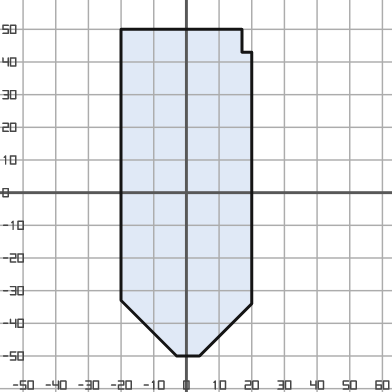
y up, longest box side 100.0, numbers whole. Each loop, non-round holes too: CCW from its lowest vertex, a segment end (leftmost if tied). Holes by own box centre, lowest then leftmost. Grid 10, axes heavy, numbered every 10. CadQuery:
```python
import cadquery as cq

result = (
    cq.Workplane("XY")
    .moveTo(-3.0, -50.0)
    .lineTo(4.0, -50.0)
    .lineTo(20.0, -34.0)
    .lineTo(20.0, 43.0)
    .lineTo(17.0, 43.0)
    .lineTo(17.0, 50.0)
    .lineTo(-20.0, 50.0)
    .lineTo(-20.0, -33.0)
    .close()
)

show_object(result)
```